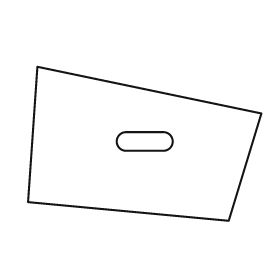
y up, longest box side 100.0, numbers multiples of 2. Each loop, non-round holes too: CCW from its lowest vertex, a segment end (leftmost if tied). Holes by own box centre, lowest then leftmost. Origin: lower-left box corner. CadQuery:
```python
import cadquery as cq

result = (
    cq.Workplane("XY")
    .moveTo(86.0, 0.0)
    .lineTo(100.0, 46.0)
    .lineTo(4.0, 66.0)
    .lineTo(0.0, 8.0)
    .close()
    .moveTo(42.0, 30.0)
    .lineTo(58.0, 30.0)
    .threePointArc((62.0, 34.0), (58.0, 38.0))
    .lineTo(42.0, 38.0)
    .threePointArc((38.0, 34.0), (42.0, 30.0))
    .close()
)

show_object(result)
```